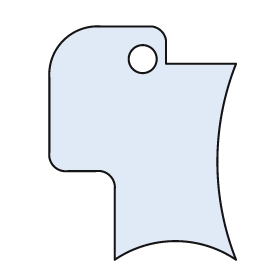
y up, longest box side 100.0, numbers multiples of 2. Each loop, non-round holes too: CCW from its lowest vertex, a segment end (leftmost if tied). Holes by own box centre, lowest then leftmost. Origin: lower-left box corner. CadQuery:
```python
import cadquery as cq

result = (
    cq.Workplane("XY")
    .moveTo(28.0, 0.0)
    .threePointArc((54.0, 8.0), (80.0, 0.0))
    .threePointArc((72.0, 42.0), (80.0, 84.0))
    .lineTo(50.0, 84.0)
    .lineTo(50.0, 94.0)
    .threePointArc((48.0, 98.0), (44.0, 100.0))
    .lineTo(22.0, 100.0)
    .threePointArc((6.0, 94.0), (0.0, 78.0))
    .lineTo(0.0, 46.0)
    .threePointArc((2.0, 40.0), (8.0, 38.0))
    .lineTo(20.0, 38.0)
    .threePointArc((26.0, 36.0), (28.0, 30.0))
    .close()
    .moveTo(40.0, 86.0)
    .circle(6.0)
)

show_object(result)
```